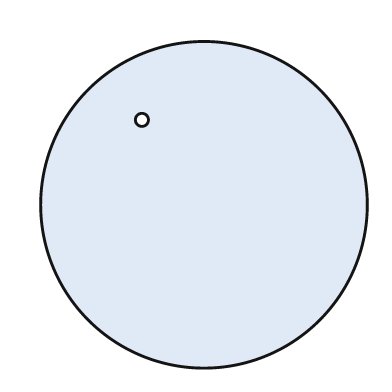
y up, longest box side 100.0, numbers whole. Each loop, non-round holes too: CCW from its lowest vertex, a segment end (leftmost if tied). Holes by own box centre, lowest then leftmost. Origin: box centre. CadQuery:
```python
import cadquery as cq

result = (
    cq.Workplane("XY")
    .moveTo(0.0, 0.0)
    .circle(50.0)
    .moveTo(-19.0, 26.0)
    .circle(2.0)
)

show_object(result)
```